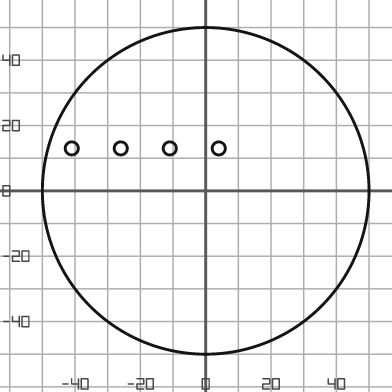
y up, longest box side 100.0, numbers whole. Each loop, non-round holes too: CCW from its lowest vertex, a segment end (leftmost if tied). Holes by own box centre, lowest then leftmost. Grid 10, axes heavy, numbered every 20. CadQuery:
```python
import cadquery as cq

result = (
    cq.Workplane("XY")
    .moveTo(0.0, 0.0)
    .circle(50.0)
    .moveTo(-41.0, 13.0)
    .circle(2.0)
    .moveTo(-26.0, 13.0)
    .circle(2.0)
    .moveTo(-11.0, 13.0)
    .circle(2.0)
    .moveTo(4.0, 13.0)
    .circle(2.0)
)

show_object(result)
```